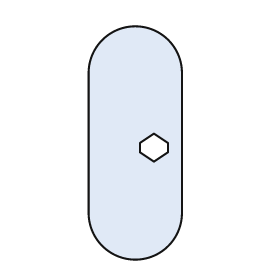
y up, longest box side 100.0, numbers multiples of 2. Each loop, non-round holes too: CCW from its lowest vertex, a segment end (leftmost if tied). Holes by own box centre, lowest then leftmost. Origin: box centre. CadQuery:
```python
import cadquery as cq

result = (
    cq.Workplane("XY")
    .moveTo(-20.0, -30.0)
    .threePointArc((0.0, -50.0), (20.0, -30.0))
    .lineTo(20.0, 30.0)
    .threePointArc((0.0, 50.0), (-20.0, 30.0))
    .close()
    .moveTo(8.0, -8.0)
    .lineTo(14.0, -4.0)
    .lineTo(14.0, 0.0)
    .lineTo(8.0, 4.0)
    .lineTo(2.0, 0.0)
    .lineTo(2.0, -4.0)
    .close()
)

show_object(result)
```